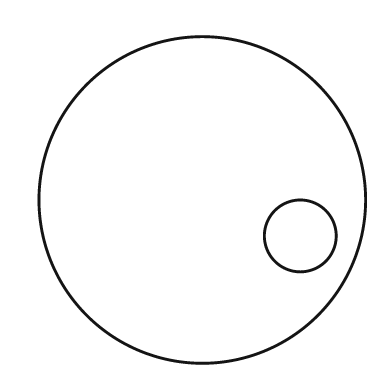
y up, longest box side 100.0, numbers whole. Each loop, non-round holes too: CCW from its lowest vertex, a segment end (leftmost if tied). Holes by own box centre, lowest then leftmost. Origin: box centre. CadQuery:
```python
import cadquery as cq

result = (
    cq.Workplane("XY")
    .moveTo(0.0, 0.0)
    .circle(50.0)
    .moveTo(30.0, -11.0)
    .circle(11.0)
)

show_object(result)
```